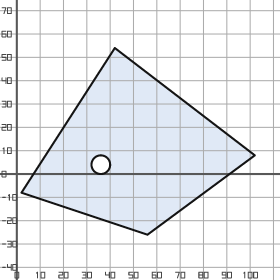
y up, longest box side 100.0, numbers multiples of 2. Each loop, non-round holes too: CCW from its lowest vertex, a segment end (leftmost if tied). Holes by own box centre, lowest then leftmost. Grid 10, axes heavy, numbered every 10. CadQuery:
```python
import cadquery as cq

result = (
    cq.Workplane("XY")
    .moveTo(56.0, -26.0)
    .lineTo(102.0, 8.0)
    .lineTo(42.0, 54.0)
    .lineTo(2.0, -8.0)
    .close()
    .moveTo(36.0, 4.0)
    .circle(4.0)
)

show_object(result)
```